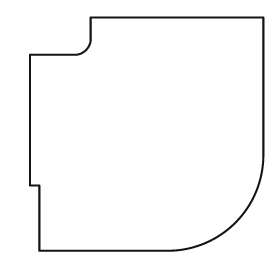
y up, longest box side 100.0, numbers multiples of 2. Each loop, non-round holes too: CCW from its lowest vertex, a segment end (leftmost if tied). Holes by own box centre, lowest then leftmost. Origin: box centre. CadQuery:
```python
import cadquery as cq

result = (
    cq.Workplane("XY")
    .moveTo(-46.0, -50.0)
    .lineTo(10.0, -50.0)
    .threePointArc((38.0, -38.0), (50.0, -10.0))
    .lineTo(50.0, 50.0)
    .lineTo(-24.0, 50.0)
    .lineTo(-24.0, 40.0)
    .threePointArc((-26.0, 36.0), (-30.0, 34.0))
    .lineTo(-50.0, 34.0)
    .lineTo(-50.0, -22.0)
    .lineTo(-46.0, -22.0)
    .close()
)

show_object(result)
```